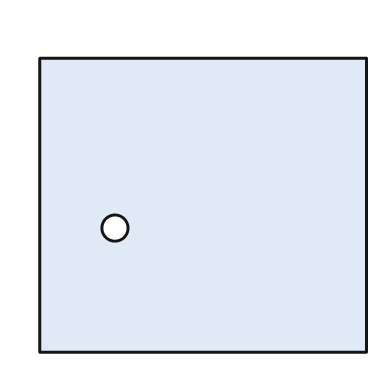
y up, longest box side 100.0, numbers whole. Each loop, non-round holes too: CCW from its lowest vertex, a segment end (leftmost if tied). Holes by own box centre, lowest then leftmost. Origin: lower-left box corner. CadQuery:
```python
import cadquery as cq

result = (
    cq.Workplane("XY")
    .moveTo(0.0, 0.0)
    .lineTo(100.0, 0.0)
    .lineTo(100.0, 90.0)
    .lineTo(0.0, 90.0)
    .close()
    .moveTo(23.0, 38.0)
    .circle(4.0)
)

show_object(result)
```